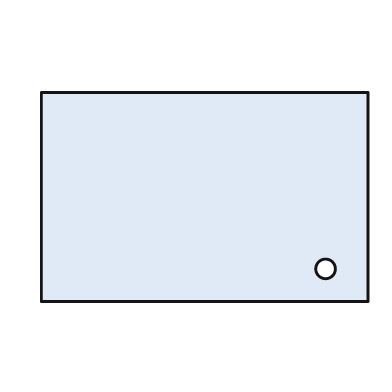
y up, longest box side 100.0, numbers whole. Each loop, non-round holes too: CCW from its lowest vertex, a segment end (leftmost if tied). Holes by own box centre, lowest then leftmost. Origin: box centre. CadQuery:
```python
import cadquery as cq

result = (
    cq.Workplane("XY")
    .moveTo(-50.0, -32.0)
    .lineTo(50.0, -32.0)
    .lineTo(50.0, 32.0)
    .lineTo(-50.0, 32.0)
    .close()
    .moveTo(37.0, -22.0)
    .circle(3.0)
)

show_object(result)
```